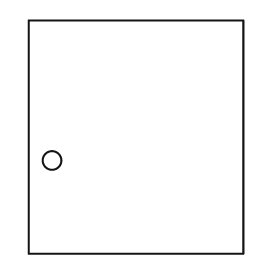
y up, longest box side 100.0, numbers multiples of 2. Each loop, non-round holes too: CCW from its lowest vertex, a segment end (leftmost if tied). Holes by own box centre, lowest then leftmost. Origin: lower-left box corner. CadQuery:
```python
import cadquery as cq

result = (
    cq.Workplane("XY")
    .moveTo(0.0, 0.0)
    .lineTo(92.0, 0.0)
    .lineTo(92.0, 100.0)
    .lineTo(0.0, 100.0)
    .close()
    .moveTo(10.0, 40.0)
    .circle(4.0)
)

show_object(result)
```